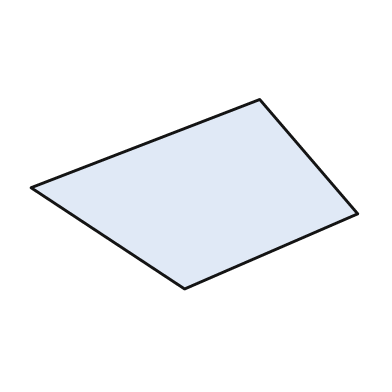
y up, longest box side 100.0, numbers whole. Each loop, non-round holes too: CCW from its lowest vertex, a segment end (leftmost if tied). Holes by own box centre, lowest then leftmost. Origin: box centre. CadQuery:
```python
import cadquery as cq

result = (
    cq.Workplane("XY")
    .moveTo(-3.0, -29.0)
    .lineTo(50.0, -6.0)
    .lineTo(20.0, 29.0)
    .lineTo(-50.0, 2.0)
    .close()
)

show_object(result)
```